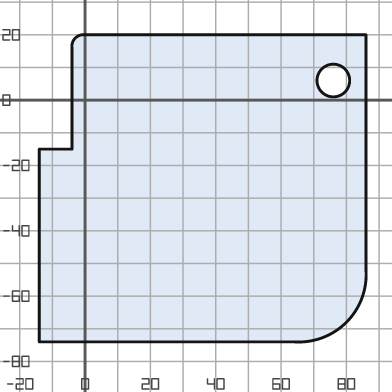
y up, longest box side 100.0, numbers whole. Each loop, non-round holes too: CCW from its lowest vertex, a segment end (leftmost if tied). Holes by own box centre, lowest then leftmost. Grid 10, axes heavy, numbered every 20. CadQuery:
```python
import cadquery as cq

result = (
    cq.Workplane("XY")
    .moveTo(-14.0, -74.0)
    .lineTo(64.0, -74.0)
    .threePointArc((80.0, -68.0), (86.0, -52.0))
    .lineTo(86.0, 20.0)
    .lineTo(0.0, 20.0)
    .threePointArc((-3.0, 19.0), (-4.0, 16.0))
    .lineTo(-4.0, -15.0)
    .lineTo(-14.0, -15.0)
    .close()
    .moveTo(76.0, 6.0)
    .circle(5.0)
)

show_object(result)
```